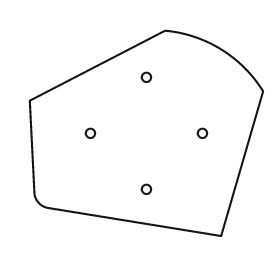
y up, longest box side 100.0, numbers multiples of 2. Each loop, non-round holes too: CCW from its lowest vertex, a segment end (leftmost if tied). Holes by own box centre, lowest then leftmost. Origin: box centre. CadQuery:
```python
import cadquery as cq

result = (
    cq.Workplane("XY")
    .moveTo(32.0, -44.0)
    .lineTo(50.0, 18.0)
    .threePointArc((32.0, 36.0), (8.0, 44.0))
    .lineTo(-50.0, 14.0)
    .lineTo(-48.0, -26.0)
    .threePointArc((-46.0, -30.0), (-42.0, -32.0))
    .close()
    .moveTo(0.0, -24.0)
    .circle(2.0)
    .moveTo(-24.0, 0.0)
    .circle(2.0)
    .moveTo(24.0, 0.0)
    .circle(2.0)
    .moveTo(0.0, 24.0)
    .circle(2.0)
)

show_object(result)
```